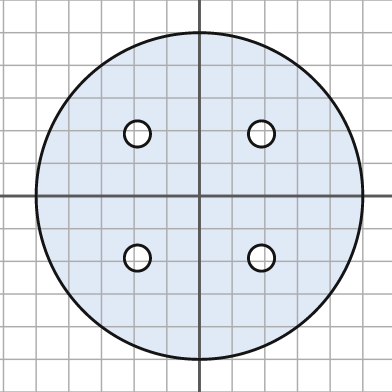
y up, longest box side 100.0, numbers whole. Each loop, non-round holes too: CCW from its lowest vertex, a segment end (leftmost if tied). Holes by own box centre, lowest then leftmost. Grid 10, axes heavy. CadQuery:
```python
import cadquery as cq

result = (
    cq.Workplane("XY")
    .moveTo(0.0, 0.0)
    .circle(50.0)
    .moveTo(-19.0, -19.0)
    .circle(4.0)
    .moveTo(19.0, -19.0)
    .circle(4.0)
    .moveTo(-19.0, 19.0)
    .circle(4.0)
    .moveTo(19.0, 19.0)
    .circle(4.0)
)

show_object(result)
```